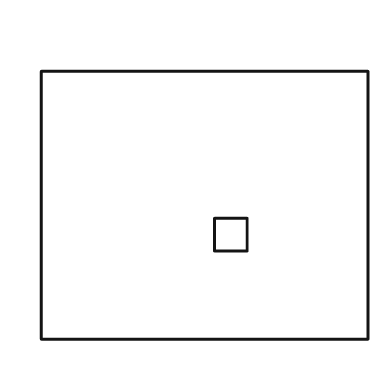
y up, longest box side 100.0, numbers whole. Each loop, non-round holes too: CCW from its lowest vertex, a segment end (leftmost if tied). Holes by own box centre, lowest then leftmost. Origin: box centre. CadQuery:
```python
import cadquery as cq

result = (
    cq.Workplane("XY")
    .moveTo(-50.0, -41.0)
    .lineTo(50.0, -41.0)
    .lineTo(50.0, 41.0)
    .lineTo(-50.0, 41.0)
    .close()
    .moveTo(3.0, -14.0)
    .lineTo(13.0, -14.0)
    .lineTo(13.0, -4.0)
    .lineTo(3.0, -4.0)
    .close()
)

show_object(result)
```